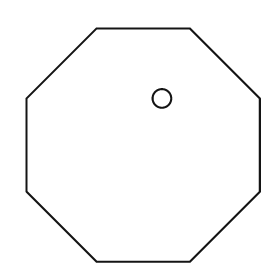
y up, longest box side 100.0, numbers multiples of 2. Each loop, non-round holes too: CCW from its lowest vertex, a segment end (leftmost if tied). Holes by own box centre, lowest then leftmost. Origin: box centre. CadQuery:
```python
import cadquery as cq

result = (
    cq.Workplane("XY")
    .moveTo(-20.0, -50.0)
    .lineTo(20.0, -50.0)
    .lineTo(50.0, -20.0)
    .lineTo(50.0, 20.0)
    .lineTo(20.0, 50.0)
    .lineTo(-20.0, 50.0)
    .lineTo(-50.0, 20.0)
    .lineTo(-50.0, -20.0)
    .close()
    .moveTo(8.0, 20.0)
    .circle(4.0)
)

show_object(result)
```